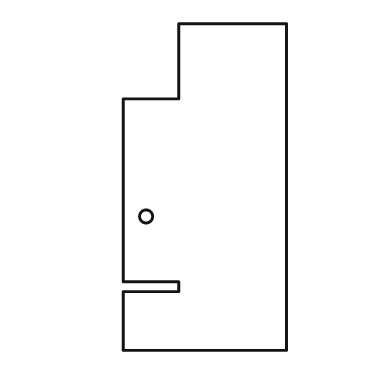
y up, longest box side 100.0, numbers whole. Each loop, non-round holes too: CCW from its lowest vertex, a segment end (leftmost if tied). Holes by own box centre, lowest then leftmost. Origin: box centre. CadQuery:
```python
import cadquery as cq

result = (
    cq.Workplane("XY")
    .moveTo(-25.0, -50.0)
    .lineTo(25.0, -50.0)
    .lineTo(25.0, 50.0)
    .lineTo(-8.0, 50.0)
    .lineTo(-8.0, 27.0)
    .lineTo(-25.0, 27.0)
    .lineTo(-25.0, -29.0)
    .lineTo(-8.0, -29.0)
    .lineTo(-8.0, -32.0)
    .lineTo(-25.0, -32.0)
    .close()
    .moveTo(-18.0, -9.0)
    .circle(2.0)
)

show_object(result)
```